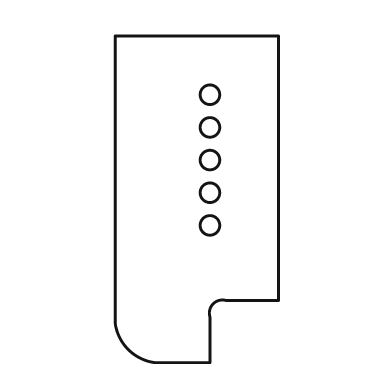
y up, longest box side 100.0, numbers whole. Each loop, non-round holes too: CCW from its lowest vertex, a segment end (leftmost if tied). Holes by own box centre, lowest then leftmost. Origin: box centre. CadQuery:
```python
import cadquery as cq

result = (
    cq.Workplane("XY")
    .moveTo(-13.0, -50.0)
    .lineTo(4.0, -50.0)
    .lineTo(4.0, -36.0)
    .threePointArc((5.0, -32.0), (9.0, -31.0))
    .lineTo(25.0, -31.0)
    .lineTo(25.0, 50.0)
    .lineTo(-25.0, 50.0)
    .lineTo(-25.0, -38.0)
    .threePointArc((-21.0, -46.0), (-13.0, -50.0))
    .close()
    .moveTo(4.0, -8.0)
    .circle(3.0)
    .moveTo(4.0, 2.0)
    .circle(3.0)
    .moveTo(4.0, 12.0)
    .circle(3.0)
    .moveTo(4.0, 22.0)
    .circle(3.0)
    .moveTo(4.0, 32.0)
    .circle(3.0)
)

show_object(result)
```